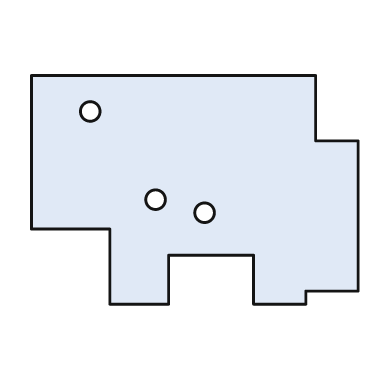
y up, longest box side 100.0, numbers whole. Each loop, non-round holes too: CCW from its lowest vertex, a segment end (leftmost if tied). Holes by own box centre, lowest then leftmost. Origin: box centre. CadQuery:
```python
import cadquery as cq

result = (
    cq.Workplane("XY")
    .moveTo(-26.0, -35.0)
    .lineTo(-8.0, -35.0)
    .lineTo(-8.0, -20.0)
    .lineTo(18.0, -20.0)
    .lineTo(18.0, -35.0)
    .lineTo(34.0, -35.0)
    .lineTo(34.0, -31.0)
    .lineTo(50.0, -31.0)
    .lineTo(50.0, 15.0)
    .lineTo(37.0, 15.0)
    .lineTo(37.0, 35.0)
    .lineTo(-50.0, 35.0)
    .lineTo(-50.0, -12.0)
    .lineTo(-26.0, -12.0)
    .close()
    .moveTo(3.0, -7.0)
    .circle(3.0)
    .moveTo(-12.0, -3.0)
    .circle(3.0)
    .moveTo(-32.0, 24.0)
    .circle(3.0)
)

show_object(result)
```